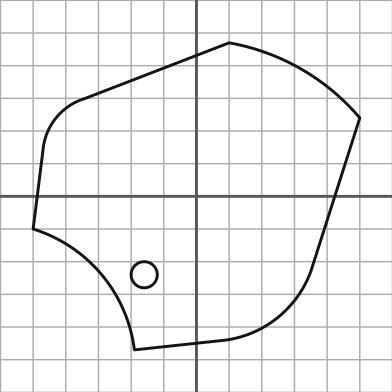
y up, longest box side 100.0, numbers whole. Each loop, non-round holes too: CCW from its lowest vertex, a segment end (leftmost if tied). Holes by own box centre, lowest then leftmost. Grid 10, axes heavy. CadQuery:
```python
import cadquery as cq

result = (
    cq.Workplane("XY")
    .moveTo(-19.0, -47.0)
    .lineTo(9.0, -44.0)
    .threePointArc((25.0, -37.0), (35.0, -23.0))
    .lineTo(50.0, 24.0)
    .threePointArc((32.0, 39.0), (10.0, 47.0))
    .lineTo(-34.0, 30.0)
    .threePointArc((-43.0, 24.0), (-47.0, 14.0))
    .lineTo(-50.0, -10.0)
    .threePointArc((-29.0, -24.0), (-19.0, -47.0))
    .close()
    .moveTo(-16.0, -24.0)
    .circle(4.0)
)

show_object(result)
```